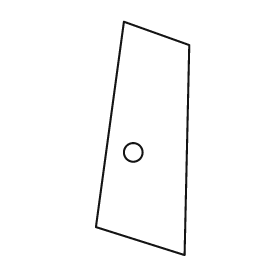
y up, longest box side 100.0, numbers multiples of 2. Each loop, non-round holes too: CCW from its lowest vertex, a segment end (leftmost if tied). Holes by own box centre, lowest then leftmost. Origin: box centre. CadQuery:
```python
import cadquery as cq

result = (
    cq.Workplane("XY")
    .moveTo(18.0, -50.0)
    .lineTo(20.0, 40.0)
    .lineTo(-8.0, 50.0)
    .lineTo(-20.0, -38.0)
    .close()
    .moveTo(-4.0, -6.0)
    .circle(4.0)
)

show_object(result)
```